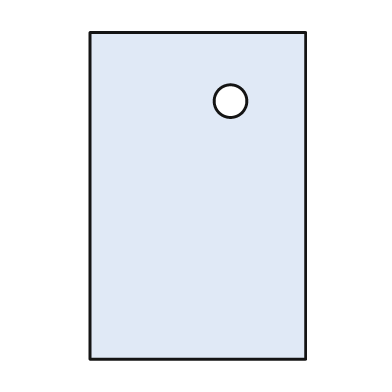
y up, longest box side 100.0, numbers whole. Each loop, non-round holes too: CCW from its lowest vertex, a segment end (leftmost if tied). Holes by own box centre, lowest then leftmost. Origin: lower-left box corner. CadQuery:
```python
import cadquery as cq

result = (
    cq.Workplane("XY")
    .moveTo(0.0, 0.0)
    .lineTo(66.0, 0.0)
    .lineTo(66.0, 100.0)
    .lineTo(0.0, 100.0)
    .close()
    .moveTo(43.0, 79.0)
    .circle(5.0)
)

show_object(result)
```